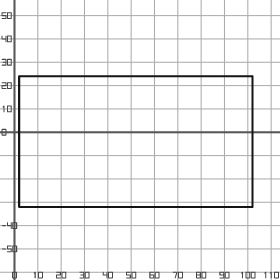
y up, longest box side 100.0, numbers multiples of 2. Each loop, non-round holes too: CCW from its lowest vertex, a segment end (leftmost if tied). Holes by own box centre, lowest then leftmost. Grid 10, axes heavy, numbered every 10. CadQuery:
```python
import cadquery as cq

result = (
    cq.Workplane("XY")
    .moveTo(2.0, -32.0)
    .lineTo(102.0, -32.0)
    .lineTo(102.0, 24.0)
    .lineTo(2.0, 24.0)
    .close()
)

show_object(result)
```